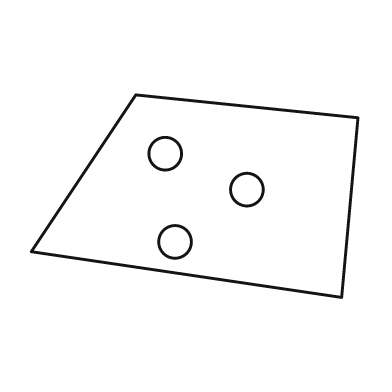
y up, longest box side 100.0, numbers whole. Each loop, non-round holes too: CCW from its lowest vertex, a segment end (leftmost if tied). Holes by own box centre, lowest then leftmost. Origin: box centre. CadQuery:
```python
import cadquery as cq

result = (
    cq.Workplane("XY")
    .moveTo(45.0, -31.0)
    .lineTo(50.0, 24.0)
    .lineTo(-18.0, 31.0)
    .lineTo(-50.0, -17.0)
    .close()
    .moveTo(-6.0, -14.0)
    .circle(5.0)
    .moveTo(16.0, 2.0)
    .circle(5.0)
    .moveTo(-9.0, 13.0)
    .circle(5.0)
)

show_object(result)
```